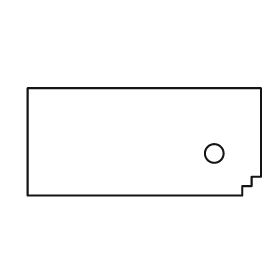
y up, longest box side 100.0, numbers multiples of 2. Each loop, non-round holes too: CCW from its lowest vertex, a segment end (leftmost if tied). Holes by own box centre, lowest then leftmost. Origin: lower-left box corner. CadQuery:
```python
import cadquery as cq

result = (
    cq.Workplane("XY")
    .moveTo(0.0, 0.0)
    .lineTo(92.0, 0.0)
    .lineTo(92.0, 4.0)
    .lineTo(96.0, 4.0)
    .lineTo(96.0, 8.0)
    .lineTo(100.0, 8.0)
    .lineTo(100.0, 46.0)
    .lineTo(0.0, 46.0)
    .close()
    .moveTo(80.0, 18.0)
    .circle(4.0)
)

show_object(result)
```